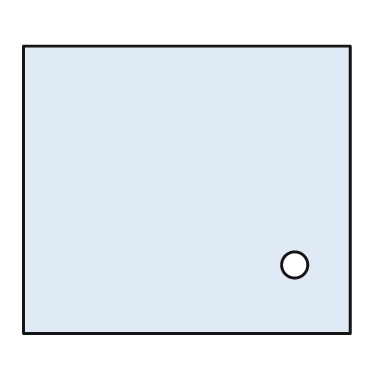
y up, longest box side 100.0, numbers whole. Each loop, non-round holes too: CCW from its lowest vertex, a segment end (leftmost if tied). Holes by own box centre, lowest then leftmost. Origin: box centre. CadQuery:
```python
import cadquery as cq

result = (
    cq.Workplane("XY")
    .moveTo(-50.0, -44.0)
    .lineTo(50.0, -44.0)
    .lineTo(50.0, 44.0)
    .lineTo(-50.0, 44.0)
    .close()
    .moveTo(33.0, -23.0)
    .circle(4.0)
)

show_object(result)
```